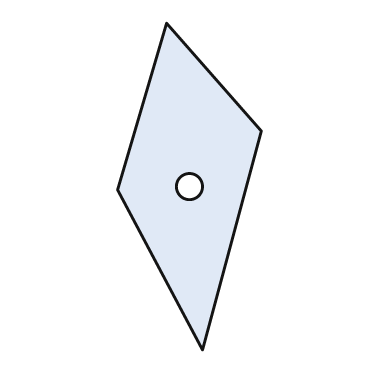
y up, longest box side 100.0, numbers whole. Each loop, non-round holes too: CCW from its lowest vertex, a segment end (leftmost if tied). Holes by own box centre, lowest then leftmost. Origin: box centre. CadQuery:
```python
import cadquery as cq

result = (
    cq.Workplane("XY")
    .moveTo(4.0, -50.0)
    .lineTo(22.0, 17.0)
    .lineTo(-7.0, 50.0)
    .lineTo(-22.0, -1.0)
    .close()
    .moveTo(0.0, 0.0)
    .circle(4.0)
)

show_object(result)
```